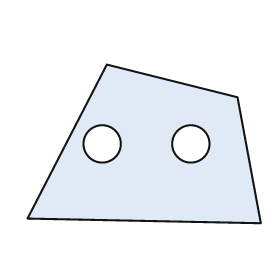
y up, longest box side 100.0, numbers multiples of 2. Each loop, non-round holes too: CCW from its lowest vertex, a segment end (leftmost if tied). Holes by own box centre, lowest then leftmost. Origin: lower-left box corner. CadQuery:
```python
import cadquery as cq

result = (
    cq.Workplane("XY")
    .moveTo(100.0, 0.0)
    .lineTo(90.0, 54.0)
    .lineTo(34.0, 68.0)
    .lineTo(0.0, 2.0)
    .close()
    .moveTo(32.0, 34.0)
    .circle(8.0)
    .moveTo(70.0, 34.0)
    .circle(8.0)
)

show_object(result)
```